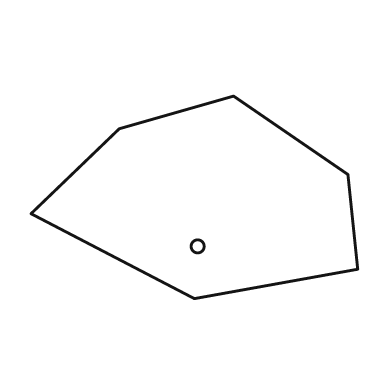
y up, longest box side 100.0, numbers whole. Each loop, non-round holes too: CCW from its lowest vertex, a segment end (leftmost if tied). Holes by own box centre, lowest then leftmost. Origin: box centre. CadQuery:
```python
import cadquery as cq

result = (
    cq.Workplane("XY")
    .moveTo(0.0, -31.0)
    .lineTo(50.0, -22.0)
    .lineTo(47.0, 7.0)
    .lineTo(12.0, 31.0)
    .lineTo(-23.0, 21.0)
    .lineTo(-50.0, -5.0)
    .close()
    .moveTo(1.0, -15.0)
    .circle(2.0)
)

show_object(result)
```